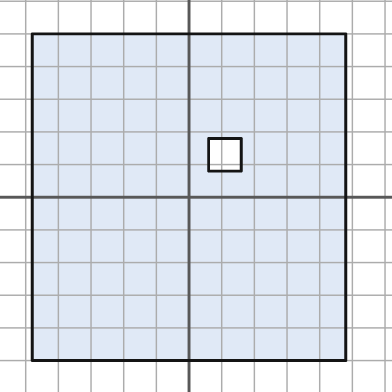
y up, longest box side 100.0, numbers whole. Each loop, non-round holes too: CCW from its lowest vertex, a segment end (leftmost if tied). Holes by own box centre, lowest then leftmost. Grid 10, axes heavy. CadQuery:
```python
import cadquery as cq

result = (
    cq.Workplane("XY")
    .moveTo(-48.0, -50.0)
    .lineTo(48.0, -50.0)
    .lineTo(48.0, 50.0)
    .lineTo(-48.0, 50.0)
    .close()
    .moveTo(6.0, 8.0)
    .lineTo(16.0, 8.0)
    .lineTo(16.0, 18.0)
    .lineTo(6.0, 18.0)
    .close()
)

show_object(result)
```